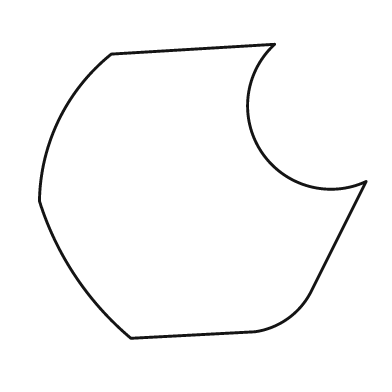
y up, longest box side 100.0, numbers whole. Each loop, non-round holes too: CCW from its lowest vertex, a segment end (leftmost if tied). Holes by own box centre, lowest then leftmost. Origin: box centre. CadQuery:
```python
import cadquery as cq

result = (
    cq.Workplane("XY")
    .moveTo(-22.0, -45.0)
    .lineTo(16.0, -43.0)
    .threePointArc((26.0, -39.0), (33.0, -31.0))
    .lineTo(50.0, 3.0)
    .threePointArc((18.0, 12.0), (22.0, 45.0))
    .lineTo(-28.0, 42.0)
    .threePointArc((-44.0, 22.0), (-50.0, -3.0))
    .threePointArc((-39.0, -26.0), (-22.0, -45.0))
    .close()
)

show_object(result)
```